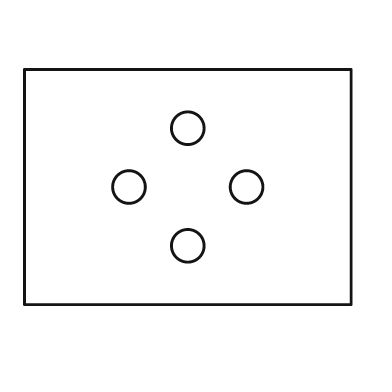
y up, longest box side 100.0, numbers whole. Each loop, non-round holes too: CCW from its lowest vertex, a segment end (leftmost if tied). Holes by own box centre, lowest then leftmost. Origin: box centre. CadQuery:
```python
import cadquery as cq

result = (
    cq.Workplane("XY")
    .moveTo(-50.0, -36.0)
    .lineTo(50.0, -36.0)
    .lineTo(50.0, 36.0)
    .lineTo(-50.0, 36.0)
    .close()
    .moveTo(0.0, -18.0)
    .circle(5.0)
    .moveTo(-18.0, 0.0)
    .circle(5.0)
    .moveTo(18.0, 0.0)
    .circle(5.0)
    .moveTo(0.0, 18.0)
    .circle(5.0)
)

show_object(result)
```